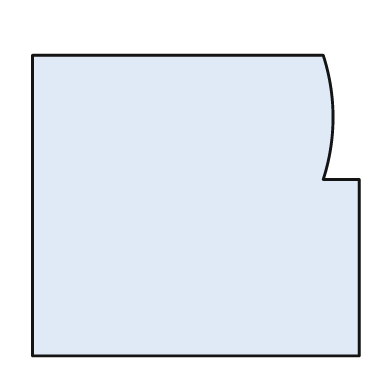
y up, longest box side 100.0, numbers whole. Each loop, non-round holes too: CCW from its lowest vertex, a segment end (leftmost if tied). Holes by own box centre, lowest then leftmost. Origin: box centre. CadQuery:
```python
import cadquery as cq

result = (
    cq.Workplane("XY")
    .moveTo(-50.0, -46.0)
    .lineTo(50.0, -46.0)
    .lineTo(50.0, 8.0)
    .lineTo(39.0, 8.0)
    .threePointArc((42.0, 27.0), (39.0, 46.0))
    .lineTo(-50.0, 46.0)
    .close()
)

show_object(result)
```